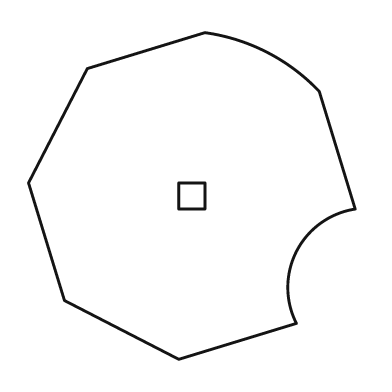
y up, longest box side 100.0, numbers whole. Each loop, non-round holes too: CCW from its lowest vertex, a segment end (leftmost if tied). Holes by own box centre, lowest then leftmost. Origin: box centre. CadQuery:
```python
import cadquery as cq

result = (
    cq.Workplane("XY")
    .moveTo(-4.0, -50.0)
    .lineTo(32.0, -39.0)
    .threePointArc((32.0, -17.0), (50.0, -4.0))
    .lineTo(39.0, 32.0)
    .threePointArc((23.0, 44.0), (4.0, 50.0))
    .lineTo(-32.0, 39.0)
    .lineTo(-50.0, 4.0)
    .lineTo(-39.0, -32.0)
    .close()
    .moveTo(-4.0, -4.0)
    .lineTo(4.0, -4.0)
    .lineTo(4.0, 4.0)
    .lineTo(-4.0, 4.0)
    .close()
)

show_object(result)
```